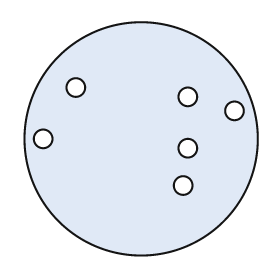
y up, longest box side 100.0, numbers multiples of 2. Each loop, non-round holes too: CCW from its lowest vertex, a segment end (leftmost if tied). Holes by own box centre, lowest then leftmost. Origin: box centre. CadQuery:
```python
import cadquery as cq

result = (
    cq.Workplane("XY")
    .moveTo(0.0, 0.0)
    .circle(50.0)
    .moveTo(18.0, -20.0)
    .circle(4.0)
    .moveTo(20.0, -4.0)
    .circle(4.0)
    .moveTo(-42.0, 0.0)
    .circle(4.0)
    .moveTo(40.0, 12.0)
    .circle(4.0)
    .moveTo(20.0, 18.0)
    .circle(4.0)
    .moveTo(-28.0, 22.0)
    .circle(4.0)
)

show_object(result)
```